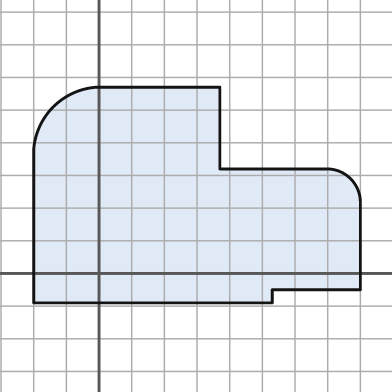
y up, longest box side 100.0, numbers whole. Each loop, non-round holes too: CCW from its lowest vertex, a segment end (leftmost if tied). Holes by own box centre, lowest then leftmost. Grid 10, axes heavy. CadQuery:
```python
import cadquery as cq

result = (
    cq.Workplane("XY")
    .moveTo(-20.0, -9.0)
    .lineTo(53.0, -9.0)
    .lineTo(53.0, -5.0)
    .lineTo(80.0, -5.0)
    .lineTo(80.0, 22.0)
    .threePointArc((77.0, 29.0), (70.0, 32.0))
    .lineTo(37.0, 32.0)
    .lineTo(37.0, 57.0)
    .lineTo(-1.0, 57.0)
    .threePointArc((-14.0, 51.0), (-20.0, 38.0))
    .close()
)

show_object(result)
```